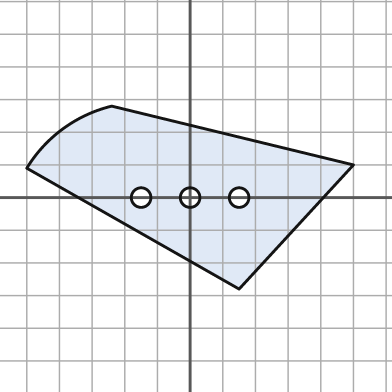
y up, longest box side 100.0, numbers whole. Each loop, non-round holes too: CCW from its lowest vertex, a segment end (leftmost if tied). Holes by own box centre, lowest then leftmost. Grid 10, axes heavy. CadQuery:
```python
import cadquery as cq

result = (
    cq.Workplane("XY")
    .moveTo(15.0, -28.0)
    .lineTo(50.0, 10.0)
    .lineTo(-24.0, 28.0)
    .threePointArc((-39.0, 21.0), (-50.0, 9.0))
    .close()
    .moveTo(-15.0, 0.0)
    .circle(3.0)
    .moveTo(0.0, 0.0)
    .circle(3.0)
    .moveTo(15.0, 0.0)
    .circle(3.0)
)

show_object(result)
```